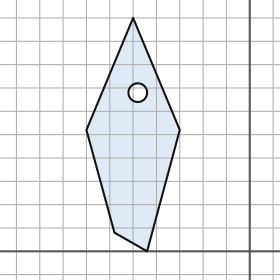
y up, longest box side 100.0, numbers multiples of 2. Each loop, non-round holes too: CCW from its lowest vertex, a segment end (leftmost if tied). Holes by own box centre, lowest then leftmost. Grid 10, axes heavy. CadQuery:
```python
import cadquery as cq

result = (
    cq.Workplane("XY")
    .moveTo(-44.0, 0.0)
    .lineTo(-30.0, 52.0)
    .lineTo(-50.0, 100.0)
    .lineTo(-70.0, 52.0)
    .lineTo(-58.0, 8.0)
    .close()
    .moveTo(-48.0, 68.0)
    .circle(4.0)
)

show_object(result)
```